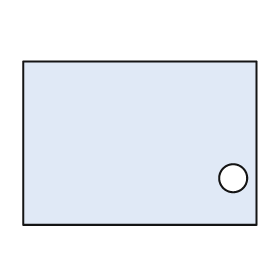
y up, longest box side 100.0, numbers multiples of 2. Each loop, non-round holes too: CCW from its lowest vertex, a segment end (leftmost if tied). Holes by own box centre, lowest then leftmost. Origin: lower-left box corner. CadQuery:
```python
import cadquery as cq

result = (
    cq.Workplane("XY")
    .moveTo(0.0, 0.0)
    .lineTo(100.0, 0.0)
    .lineTo(100.0, 70.0)
    .lineTo(0.0, 70.0)
    .close()
    .moveTo(90.0, 20.0)
    .circle(6.0)
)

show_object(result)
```